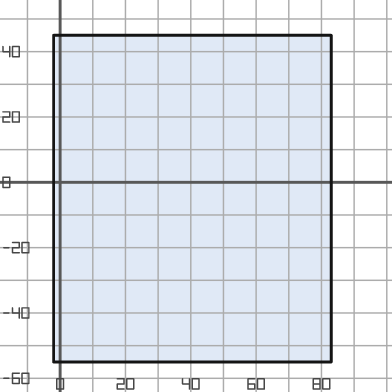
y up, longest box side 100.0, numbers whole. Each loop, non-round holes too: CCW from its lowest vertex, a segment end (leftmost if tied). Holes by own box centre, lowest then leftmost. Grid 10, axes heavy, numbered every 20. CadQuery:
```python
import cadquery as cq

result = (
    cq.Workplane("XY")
    .moveTo(-2.0, -55.0)
    .lineTo(83.0, -55.0)
    .lineTo(83.0, 45.0)
    .lineTo(-2.0, 45.0)
    .close()
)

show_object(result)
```